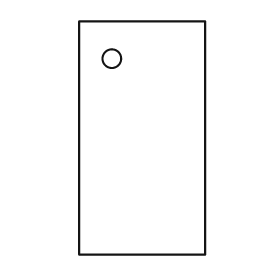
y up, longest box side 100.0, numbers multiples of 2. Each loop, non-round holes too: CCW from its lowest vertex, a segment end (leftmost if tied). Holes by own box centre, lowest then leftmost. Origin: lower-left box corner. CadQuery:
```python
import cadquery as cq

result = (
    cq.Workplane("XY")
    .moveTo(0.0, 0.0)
    .lineTo(54.0, 0.0)
    .lineTo(54.0, 100.0)
    .lineTo(0.0, 100.0)
    .close()
    .moveTo(14.0, 84.0)
    .circle(4.0)
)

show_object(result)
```